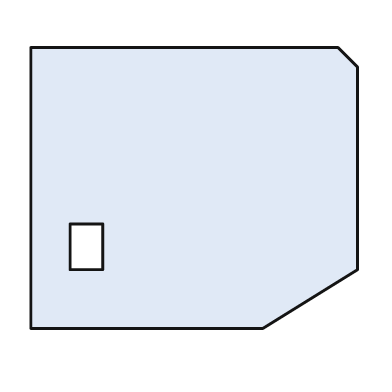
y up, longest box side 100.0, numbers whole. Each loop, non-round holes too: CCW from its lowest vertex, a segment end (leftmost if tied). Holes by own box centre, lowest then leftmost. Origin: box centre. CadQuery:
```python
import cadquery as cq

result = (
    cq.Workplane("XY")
    .moveTo(-50.0, -43.0)
    .lineTo(21.0, -43.0)
    .lineTo(50.0, -25.0)
    .lineTo(50.0, 37.0)
    .lineTo(44.0, 43.0)
    .lineTo(-50.0, 43.0)
    .close()
    .moveTo(-38.0, -25.0)
    .lineTo(-28.0, -25.0)
    .lineTo(-28.0, -11.0)
    .lineTo(-38.0, -11.0)
    .close()
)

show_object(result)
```